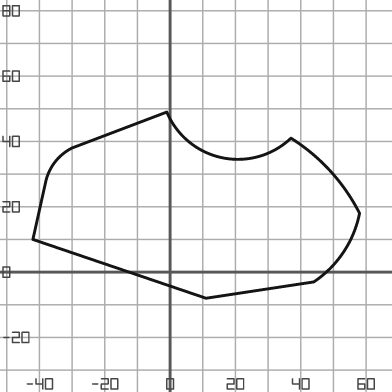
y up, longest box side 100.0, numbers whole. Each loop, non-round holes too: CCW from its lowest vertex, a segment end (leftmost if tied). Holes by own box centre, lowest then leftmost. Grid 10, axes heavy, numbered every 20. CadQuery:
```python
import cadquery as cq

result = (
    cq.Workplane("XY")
    .moveTo(11.0, -8.0)
    .lineTo(44.0, -3.0)
    .threePointArc((53.0, 6.0), (58.0, 18.0))
    .threePointArc((49.0, 31.0), (37.0, 41.0))
    .threePointArc((16.0, 35.0), (-1.0, 49.0))
    .lineTo(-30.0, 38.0)
    .threePointArc((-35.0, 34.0), (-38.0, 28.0))
    .lineTo(-42.0, 10.0)
    .close()
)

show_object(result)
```